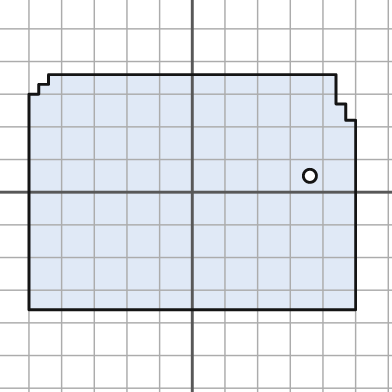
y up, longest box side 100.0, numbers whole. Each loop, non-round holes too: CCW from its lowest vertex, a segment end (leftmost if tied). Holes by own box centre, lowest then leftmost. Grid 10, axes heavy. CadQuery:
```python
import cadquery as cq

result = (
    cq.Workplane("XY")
    .moveTo(-50.0, -36.0)
    .lineTo(50.0, -36.0)
    .lineTo(50.0, 22.0)
    .lineTo(47.0, 22.0)
    .lineTo(47.0, 27.0)
    .lineTo(44.0, 27.0)
    .lineTo(44.0, 36.0)
    .lineTo(-44.0, 36.0)
    .lineTo(-44.0, 33.0)
    .lineTo(-47.0, 33.0)
    .lineTo(-47.0, 30.0)
    .lineTo(-50.0, 30.0)
    .close()
    .moveTo(36.0, 5.0)
    .circle(2.0)
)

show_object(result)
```